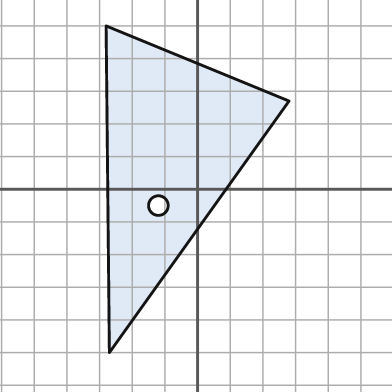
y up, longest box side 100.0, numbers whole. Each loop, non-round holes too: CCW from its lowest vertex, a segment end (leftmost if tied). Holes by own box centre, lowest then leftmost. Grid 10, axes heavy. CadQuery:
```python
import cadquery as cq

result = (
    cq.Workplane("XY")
    .moveTo(-27.0, -50.0)
    .lineTo(28.0, 27.0)
    .lineTo(-28.0, 50.0)
    .close()
    .moveTo(-12.0, -5.0)
    .circle(3.0)
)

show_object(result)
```